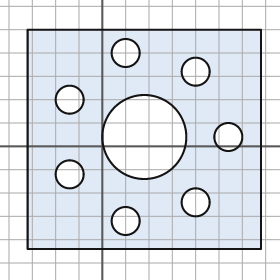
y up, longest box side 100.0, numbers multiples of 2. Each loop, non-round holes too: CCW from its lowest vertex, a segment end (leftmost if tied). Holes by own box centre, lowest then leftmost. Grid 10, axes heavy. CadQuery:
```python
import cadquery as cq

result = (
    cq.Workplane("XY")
    .moveTo(-32.0, -44.0)
    .lineTo(68.0, -44.0)
    .lineTo(68.0, 50.0)
    .lineTo(-32.0, 50.0)
    .close()
    .moveTo(10.0, -32.0)
    .circle(6.0)
    .moveTo(40.0, -24.0)
    .circle(6.0)
    .moveTo(-14.0, -12.0)
    .circle(6.0)
    .moveTo(18.0, 4.0)
    .circle(18.0)
    .moveTo(54.0, 4.0)
    .circle(6.0)
    .moveTo(-14.0, 20.0)
    .circle(6.0)
    .moveTo(40.0, 32.0)
    .circle(6.0)
    .moveTo(10.0, 40.0)
    .circle(6.0)
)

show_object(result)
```